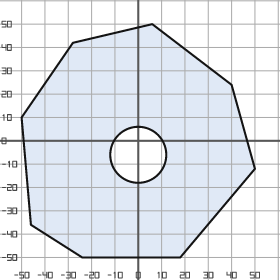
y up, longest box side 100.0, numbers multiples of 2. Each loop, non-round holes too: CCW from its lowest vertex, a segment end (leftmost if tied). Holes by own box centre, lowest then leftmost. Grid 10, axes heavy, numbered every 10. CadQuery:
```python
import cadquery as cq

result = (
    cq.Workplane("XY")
    .moveTo(-24.0, -50.0)
    .lineTo(18.0, -50.0)
    .lineTo(50.0, -12.0)
    .lineTo(40.0, 24.0)
    .lineTo(6.0, 50.0)
    .lineTo(-28.0, 42.0)
    .lineTo(-50.0, 10.0)
    .lineTo(-46.0, -36.0)
    .close()
    .moveTo(0.0, -6.0)
    .circle(12.0)
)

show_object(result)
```